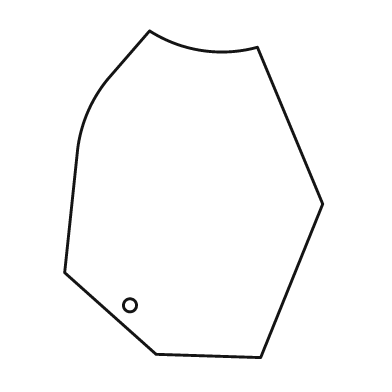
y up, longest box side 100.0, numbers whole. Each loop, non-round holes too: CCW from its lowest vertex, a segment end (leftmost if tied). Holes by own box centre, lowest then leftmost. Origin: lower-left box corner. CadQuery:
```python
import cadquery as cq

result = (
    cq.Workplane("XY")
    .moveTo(60.0, 0.0)
    .lineTo(79.0, 47.0)
    .lineTo(59.0, 95.0)
    .threePointArc((42.0, 94.0), (26.0, 100.0))
    .lineTo(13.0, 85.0)
    .threePointArc((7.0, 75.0), (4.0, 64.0))
    .lineTo(0.0, 26.0)
    .lineTo(28.0, 1.0)
    .close()
    .moveTo(20.0, 16.0)
    .circle(2.0)
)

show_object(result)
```